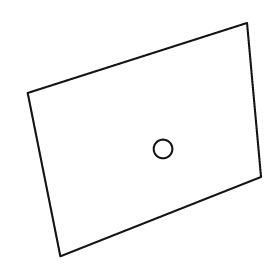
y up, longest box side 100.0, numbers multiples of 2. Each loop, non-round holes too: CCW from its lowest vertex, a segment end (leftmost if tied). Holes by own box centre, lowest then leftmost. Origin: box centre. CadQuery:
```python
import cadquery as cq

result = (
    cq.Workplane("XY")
    .moveTo(-36.0, -50.0)
    .lineTo(50.0, -16.0)
    .lineTo(44.0, 50.0)
    .lineTo(-50.0, 20.0)
    .close()
    .moveTo(8.0, -4.0)
    .circle(4.0)
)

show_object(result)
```